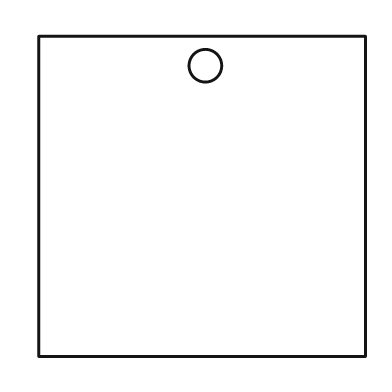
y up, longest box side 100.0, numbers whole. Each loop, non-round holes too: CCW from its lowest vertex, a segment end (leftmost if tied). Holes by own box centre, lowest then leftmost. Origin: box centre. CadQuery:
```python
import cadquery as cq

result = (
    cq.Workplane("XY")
    .moveTo(-50.0, -49.0)
    .lineTo(50.0, -49.0)
    .lineTo(50.0, 49.0)
    .lineTo(-50.0, 49.0)
    .close()
    .moveTo(1.0, 40.0)
    .circle(5.0)
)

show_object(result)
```